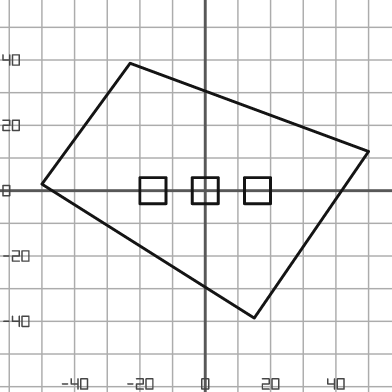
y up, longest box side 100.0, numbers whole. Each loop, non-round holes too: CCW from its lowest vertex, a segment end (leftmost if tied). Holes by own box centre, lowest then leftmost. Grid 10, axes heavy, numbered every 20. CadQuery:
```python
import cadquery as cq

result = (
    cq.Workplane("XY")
    .moveTo(15.0, -39.0)
    .lineTo(50.0, 12.0)
    .lineTo(-23.0, 39.0)
    .lineTo(-50.0, 2.0)
    .close()
    .moveTo(-20.0, -4.0)
    .lineTo(-12.0, -4.0)
    .lineTo(-12.0, 4.0)
    .lineTo(-20.0, 4.0)
    .close()
    .moveTo(-4.0, -4.0)
    .lineTo(4.0, -4.0)
    .lineTo(4.0, 4.0)
    .lineTo(-4.0, 4.0)
    .close()
    .moveTo(12.0, -4.0)
    .lineTo(20.0, -4.0)
    .lineTo(20.0, 4.0)
    .lineTo(12.0, 4.0)
    .close()
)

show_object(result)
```